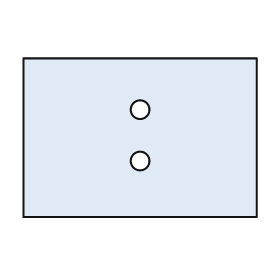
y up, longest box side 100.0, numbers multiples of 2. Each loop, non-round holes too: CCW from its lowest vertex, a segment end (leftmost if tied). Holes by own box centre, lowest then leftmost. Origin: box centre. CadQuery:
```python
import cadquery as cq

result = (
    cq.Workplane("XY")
    .moveTo(-50.0, -34.0)
    .lineTo(50.0, -34.0)
    .lineTo(50.0, 34.0)
    .lineTo(-50.0, 34.0)
    .close()
    .moveTo(0.0, -10.0)
    .circle(4.0)
    .moveTo(0.0, 12.0)
    .circle(4.0)
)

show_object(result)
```